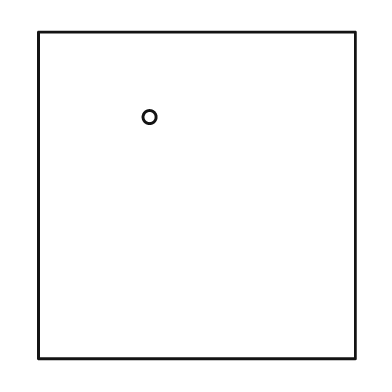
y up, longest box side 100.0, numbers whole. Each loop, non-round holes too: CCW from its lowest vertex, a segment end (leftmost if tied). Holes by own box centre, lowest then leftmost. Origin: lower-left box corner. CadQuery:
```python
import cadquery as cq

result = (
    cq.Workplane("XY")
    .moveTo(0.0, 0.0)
    .lineTo(97.0, 0.0)
    .lineTo(97.0, 100.0)
    .lineTo(0.0, 100.0)
    .close()
    .moveTo(34.0, 74.0)
    .circle(2.0)
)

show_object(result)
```